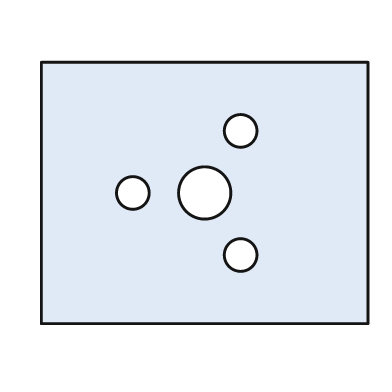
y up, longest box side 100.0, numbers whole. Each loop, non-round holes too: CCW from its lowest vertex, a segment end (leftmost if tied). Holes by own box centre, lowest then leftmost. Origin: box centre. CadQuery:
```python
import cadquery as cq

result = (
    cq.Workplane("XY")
    .moveTo(-50.0, -40.0)
    .lineTo(50.0, -40.0)
    .lineTo(50.0, 40.0)
    .lineTo(-50.0, 40.0)
    .close()
    .moveTo(11.0, -19.0)
    .circle(5.0)
    .moveTo(-22.0, 0.0)
    .circle(5.0)
    .moveTo(0.0, 0.0)
    .circle(8.0)
    .moveTo(11.0, 19.0)
    .circle(5.0)
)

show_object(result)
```